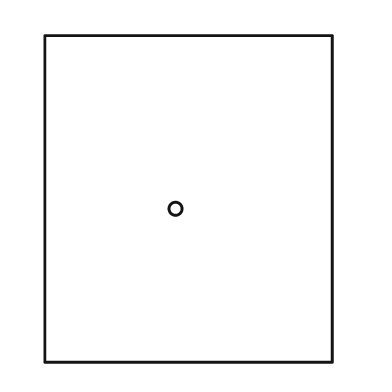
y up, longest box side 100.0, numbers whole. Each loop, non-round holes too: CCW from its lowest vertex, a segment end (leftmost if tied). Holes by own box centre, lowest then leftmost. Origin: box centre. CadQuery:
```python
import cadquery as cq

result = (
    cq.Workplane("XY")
    .moveTo(-44.0, -50.0)
    .lineTo(44.0, -50.0)
    .lineTo(44.0, 50.0)
    .lineTo(-44.0, 50.0)
    .close()
    .moveTo(-4.0, -3.0)
    .circle(2.0)
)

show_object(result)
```